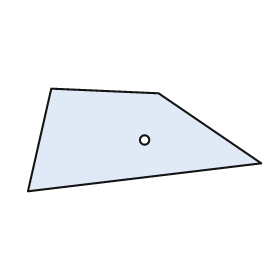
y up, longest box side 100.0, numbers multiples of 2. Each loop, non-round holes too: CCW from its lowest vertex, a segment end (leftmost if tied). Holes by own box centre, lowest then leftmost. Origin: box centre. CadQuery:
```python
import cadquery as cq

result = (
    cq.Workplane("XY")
    .moveTo(-50.0, -22.0)
    .lineTo(50.0, -10.0)
    .lineTo(6.0, 20.0)
    .lineTo(-40.0, 22.0)
    .close()
    .moveTo(0.0, 0.0)
    .circle(2.0)
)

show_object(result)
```